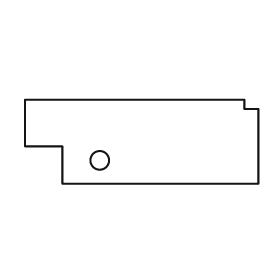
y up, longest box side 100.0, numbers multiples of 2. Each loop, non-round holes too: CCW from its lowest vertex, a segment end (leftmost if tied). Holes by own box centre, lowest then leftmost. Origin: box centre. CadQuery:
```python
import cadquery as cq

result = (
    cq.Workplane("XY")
    .moveTo(-34.0, -18.0)
    .lineTo(50.0, -18.0)
    .lineTo(50.0, 14.0)
    .lineTo(44.0, 14.0)
    .lineTo(44.0, 18.0)
    .lineTo(-50.0, 18.0)
    .lineTo(-50.0, -2.0)
    .lineTo(-34.0, -2.0)
    .close()
    .moveTo(-18.0, -8.0)
    .circle(4.0)
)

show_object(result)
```